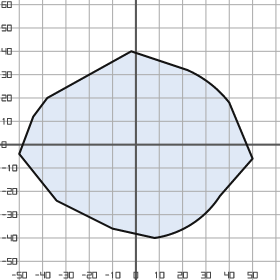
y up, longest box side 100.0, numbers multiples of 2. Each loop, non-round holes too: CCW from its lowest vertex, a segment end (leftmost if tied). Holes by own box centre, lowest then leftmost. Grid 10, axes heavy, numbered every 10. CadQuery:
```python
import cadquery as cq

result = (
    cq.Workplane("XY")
    .moveTo(8.0, -40.0)
    .threePointArc((24.0, -34.0), (36.0, -22.0))
    .lineTo(50.0, -6.0)
    .lineTo(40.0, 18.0)
    .threePointArc((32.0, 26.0), (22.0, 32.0))
    .lineTo(-2.0, 40.0)
    .lineTo(-38.0, 20.0)
    .lineTo(-44.0, 12.0)
    .lineTo(-50.0, -4.0)
    .lineTo(-34.0, -24.0)
    .lineTo(-10.0, -36.0)
    .close()
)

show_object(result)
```